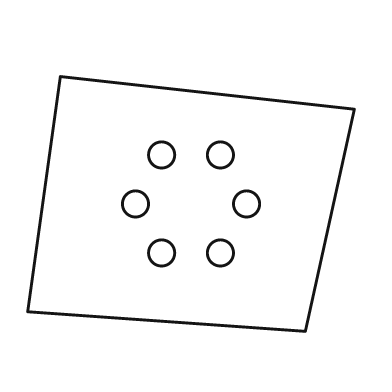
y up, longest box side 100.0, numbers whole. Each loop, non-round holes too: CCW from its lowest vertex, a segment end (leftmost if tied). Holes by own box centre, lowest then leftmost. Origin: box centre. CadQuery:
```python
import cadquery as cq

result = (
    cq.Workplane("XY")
    .moveTo(35.0, -39.0)
    .lineTo(50.0, 29.0)
    .lineTo(-40.0, 39.0)
    .lineTo(-50.0, -33.0)
    .close()
    .moveTo(-9.0, -15.0)
    .circle(4.0)
    .moveTo(9.0, -15.0)
    .circle(4.0)
    .moveTo(-17.0, 0.0)
    .circle(4.0)
    .moveTo(17.0, 0.0)
    .circle(4.0)
    .moveTo(-9.0, 15.0)
    .circle(4.0)
    .moveTo(9.0, 15.0)
    .circle(4.0)
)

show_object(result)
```